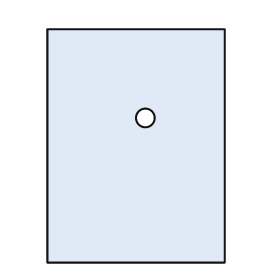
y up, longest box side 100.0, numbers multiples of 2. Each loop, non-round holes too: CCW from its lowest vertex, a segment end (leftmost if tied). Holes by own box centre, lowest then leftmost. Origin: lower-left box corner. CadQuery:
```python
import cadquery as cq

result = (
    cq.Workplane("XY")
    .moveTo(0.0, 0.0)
    .lineTo(76.0, 0.0)
    .lineTo(76.0, 100.0)
    .lineTo(0.0, 100.0)
    .close()
    .moveTo(42.0, 62.0)
    .circle(4.0)
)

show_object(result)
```